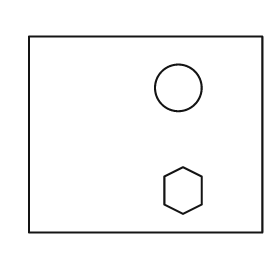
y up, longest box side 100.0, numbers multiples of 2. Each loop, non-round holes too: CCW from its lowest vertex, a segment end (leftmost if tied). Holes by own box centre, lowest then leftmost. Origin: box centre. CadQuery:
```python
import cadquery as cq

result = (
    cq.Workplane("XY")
    .moveTo(-50.0, -42.0)
    .lineTo(50.0, -42.0)
    .lineTo(50.0, 42.0)
    .lineTo(-50.0, 42.0)
    .close()
    .moveTo(16.0, -34.0)
    .lineTo(24.0, -30.0)
    .lineTo(24.0, -18.0)
    .lineTo(16.0, -14.0)
    .lineTo(8.0, -18.0)
    .lineTo(8.0, -30.0)
    .close()
    .moveTo(14.0, 20.0)
    .circle(10.0)
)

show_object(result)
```